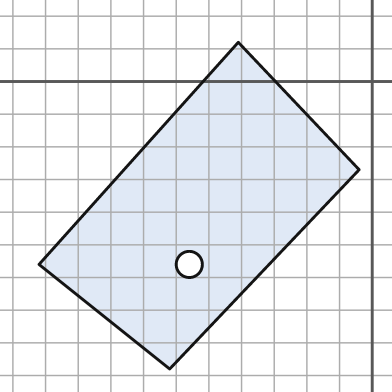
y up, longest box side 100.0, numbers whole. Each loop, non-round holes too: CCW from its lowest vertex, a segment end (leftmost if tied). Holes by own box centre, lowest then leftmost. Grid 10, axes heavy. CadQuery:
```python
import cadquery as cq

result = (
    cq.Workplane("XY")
    .moveTo(-62.0, -88.0)
    .lineTo(-4.0, -27.0)
    .lineTo(-41.0, 12.0)
    .lineTo(-102.0, -56.0)
    .close()
    .moveTo(-56.0, -56.0)
    .circle(4.0)
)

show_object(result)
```